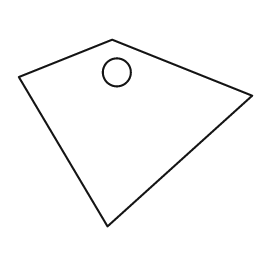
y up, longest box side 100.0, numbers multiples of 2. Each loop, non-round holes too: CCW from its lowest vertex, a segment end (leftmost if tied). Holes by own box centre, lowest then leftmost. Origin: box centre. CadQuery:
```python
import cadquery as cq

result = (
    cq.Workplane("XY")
    .moveTo(-12.0, -40.0)
    .lineTo(50.0, 16.0)
    .lineTo(-10.0, 40.0)
    .lineTo(-50.0, 24.0)
    .close()
    .moveTo(-8.0, 26.0)
    .circle(6.0)
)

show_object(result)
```